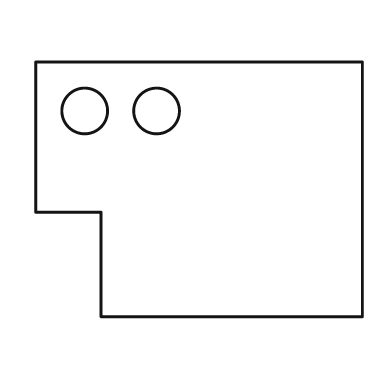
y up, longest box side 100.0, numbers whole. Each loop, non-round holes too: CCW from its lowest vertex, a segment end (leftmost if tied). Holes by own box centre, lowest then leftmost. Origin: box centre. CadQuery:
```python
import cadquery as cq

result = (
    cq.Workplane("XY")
    .moveTo(-30.0, -39.0)
    .lineTo(50.0, -39.0)
    .lineTo(50.0, 39.0)
    .lineTo(-50.0, 39.0)
    .lineTo(-50.0, -7.0)
    .lineTo(-30.0, -7.0)
    .close()
    .moveTo(-35.0, 24.0)
    .circle(7.0)
    .moveTo(-13.0, 24.0)
    .circle(7.0)
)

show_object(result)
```